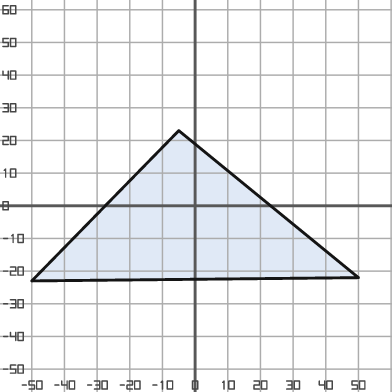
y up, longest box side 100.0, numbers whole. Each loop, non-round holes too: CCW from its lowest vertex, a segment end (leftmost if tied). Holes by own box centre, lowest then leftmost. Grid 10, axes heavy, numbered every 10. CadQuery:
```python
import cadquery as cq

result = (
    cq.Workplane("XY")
    .moveTo(-50.0, -23.0)
    .lineTo(50.0, -22.0)
    .lineTo(-5.0, 23.0)
    .close()
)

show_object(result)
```